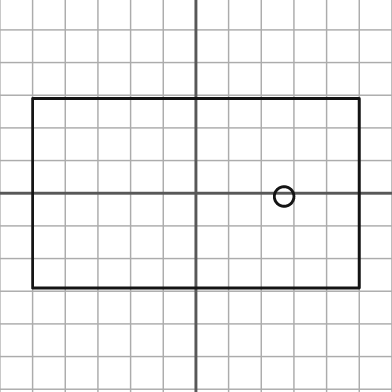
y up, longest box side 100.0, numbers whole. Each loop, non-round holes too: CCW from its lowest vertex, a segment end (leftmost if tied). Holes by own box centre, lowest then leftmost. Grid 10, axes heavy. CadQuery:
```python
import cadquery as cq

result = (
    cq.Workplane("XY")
    .moveTo(-50.0, -29.0)
    .lineTo(50.0, -29.0)
    .lineTo(50.0, 29.0)
    .lineTo(-50.0, 29.0)
    .close()
    .moveTo(27.0, -1.0)
    .circle(3.0)
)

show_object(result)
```